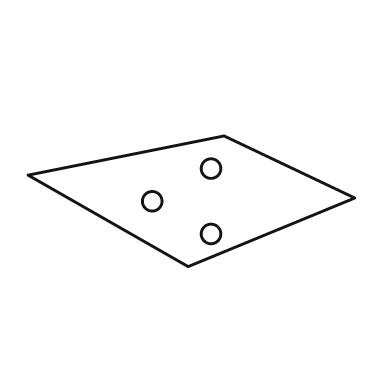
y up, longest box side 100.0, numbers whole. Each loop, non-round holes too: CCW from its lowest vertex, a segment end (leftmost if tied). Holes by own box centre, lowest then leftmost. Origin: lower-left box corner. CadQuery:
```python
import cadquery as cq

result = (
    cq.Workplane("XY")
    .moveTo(49.0, 0.0)
    .lineTo(100.0, 21.0)
    .lineTo(60.0, 40.0)
    .lineTo(0.0, 28.0)
    .close()
    .moveTo(56.0, 10.0)
    .circle(3.0)
    .moveTo(38.0, 20.0)
    .circle(3.0)
    .moveTo(56.0, 30.0)
    .circle(3.0)
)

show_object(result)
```